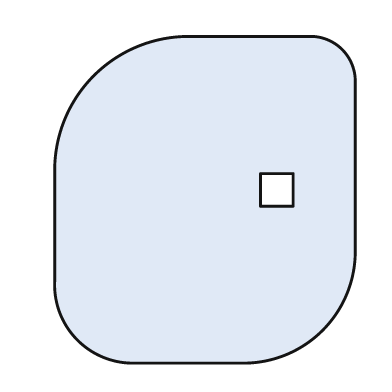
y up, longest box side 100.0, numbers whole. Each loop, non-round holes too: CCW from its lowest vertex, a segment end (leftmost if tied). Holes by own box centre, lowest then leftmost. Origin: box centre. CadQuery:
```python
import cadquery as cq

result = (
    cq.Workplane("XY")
    .moveTo(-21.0, -50.0)
    .lineTo(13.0, -50.0)
    .threePointArc((36.0, -40.0), (46.0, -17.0))
    .lineTo(46.0, 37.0)
    .threePointArc((42.0, 46.0), (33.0, 50.0))
    .lineTo(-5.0, 50.0)
    .threePointArc((-34.0, 38.0), (-46.0, 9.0))
    .lineTo(-46.0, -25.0)
    .threePointArc((-39.0, -43.0), (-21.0, -50.0))
    .close()
    .moveTo(17.0, -2.0)
    .lineTo(27.0, -2.0)
    .lineTo(27.0, 8.0)
    .lineTo(17.0, 8.0)
    .close()
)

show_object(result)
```